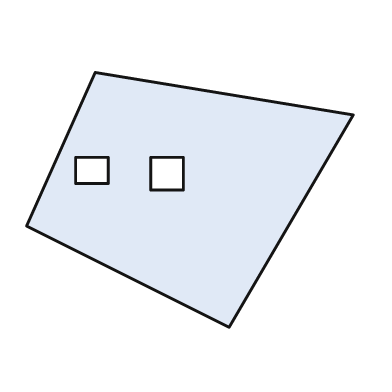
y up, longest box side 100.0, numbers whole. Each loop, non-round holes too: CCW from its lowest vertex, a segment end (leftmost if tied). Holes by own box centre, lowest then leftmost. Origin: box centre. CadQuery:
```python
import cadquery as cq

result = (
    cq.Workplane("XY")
    .moveTo(12.0, -39.0)
    .lineTo(50.0, 26.0)
    .lineTo(-29.0, 39.0)
    .lineTo(-50.0, -8.0)
    .close()
    .moveTo(-12.0, 3.0)
    .lineTo(-2.0, 3.0)
    .lineTo(-2.0, 13.0)
    .lineTo(-12.0, 13.0)
    .close()
    .moveTo(-35.0, 5.0)
    .lineTo(-25.0, 5.0)
    .lineTo(-25.0, 13.0)
    .lineTo(-35.0, 13.0)
    .close()
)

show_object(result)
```